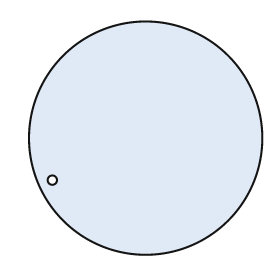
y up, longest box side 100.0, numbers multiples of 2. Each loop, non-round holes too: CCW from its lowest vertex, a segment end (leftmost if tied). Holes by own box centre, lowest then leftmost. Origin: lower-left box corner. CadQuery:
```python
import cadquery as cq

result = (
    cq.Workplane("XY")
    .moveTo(50.0, 50.0)
    .circle(50.0)
    .moveTo(10.0, 32.0)
    .circle(2.0)
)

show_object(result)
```